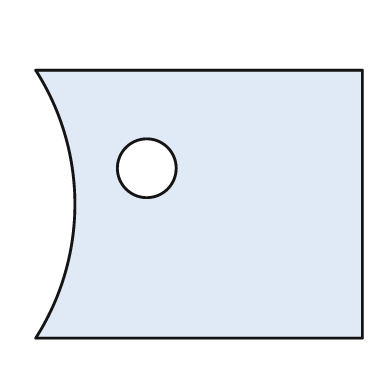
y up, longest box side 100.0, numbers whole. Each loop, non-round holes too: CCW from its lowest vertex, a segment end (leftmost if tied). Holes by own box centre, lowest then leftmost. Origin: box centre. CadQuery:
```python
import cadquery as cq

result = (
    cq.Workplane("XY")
    .moveTo(-50.0, -41.0)
    .lineTo(50.0, -41.0)
    .lineTo(50.0, 41.0)
    .lineTo(-50.0, 41.0)
    .threePointArc((-38.0, 0.0), (-50.0, -41.0))
    .close()
    .moveTo(-16.0, 11.0)
    .circle(9.0)
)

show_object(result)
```